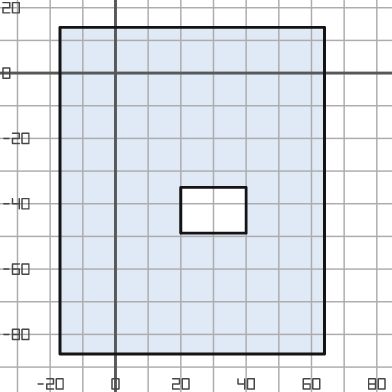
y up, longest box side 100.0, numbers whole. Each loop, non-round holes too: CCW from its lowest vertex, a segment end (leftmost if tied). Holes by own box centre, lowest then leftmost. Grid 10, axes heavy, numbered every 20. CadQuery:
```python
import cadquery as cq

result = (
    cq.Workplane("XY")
    .moveTo(-17.0, -86.0)
    .lineTo(64.0, -86.0)
    .lineTo(64.0, 14.0)
    .lineTo(-17.0, 14.0)
    .close()
    .moveTo(20.0, -49.0)
    .lineTo(40.0, -49.0)
    .lineTo(40.0, -35.0)
    .lineTo(20.0, -35.0)
    .close()
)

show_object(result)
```